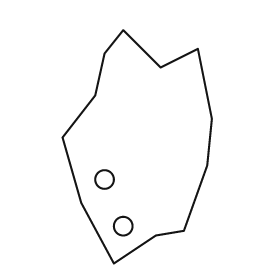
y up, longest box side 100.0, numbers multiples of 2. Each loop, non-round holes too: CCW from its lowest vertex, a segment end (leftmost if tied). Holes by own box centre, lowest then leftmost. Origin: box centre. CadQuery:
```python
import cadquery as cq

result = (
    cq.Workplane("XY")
    .moveTo(-10.0, -50.0)
    .lineTo(8.0, -38.0)
    .lineTo(20.0, -36.0)
    .lineTo(30.0, -8.0)
    .lineTo(32.0, 12.0)
    .lineTo(26.0, 42.0)
    .lineTo(10.0, 34.0)
    .lineTo(-6.0, 50.0)
    .lineTo(-14.0, 40.0)
    .lineTo(-18.0, 22.0)
    .lineTo(-32.0, 4.0)
    .lineTo(-24.0, -24.0)
    .close()
    .moveTo(-6.0, -34.0)
    .circle(4.0)
    .moveTo(-14.0, -14.0)
    .circle(4.0)
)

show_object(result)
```